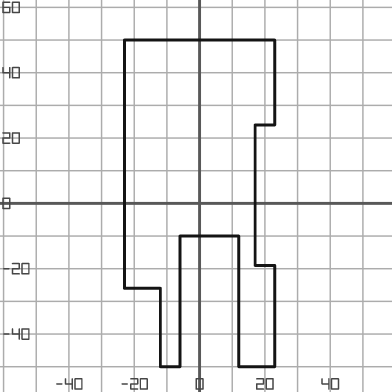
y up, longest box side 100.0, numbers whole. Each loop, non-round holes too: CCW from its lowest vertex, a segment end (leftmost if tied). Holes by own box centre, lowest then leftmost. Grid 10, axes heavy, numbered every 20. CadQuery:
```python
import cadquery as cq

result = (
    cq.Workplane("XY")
    .moveTo(-12.0, -50.0)
    .lineTo(-6.0, -50.0)
    .lineTo(-6.0, -10.0)
    .lineTo(12.0, -10.0)
    .lineTo(12.0, -50.0)
    .lineTo(23.0, -50.0)
    .lineTo(23.0, -19.0)
    .lineTo(17.0, -19.0)
    .lineTo(17.0, 24.0)
    .lineTo(23.0, 24.0)
    .lineTo(23.0, 50.0)
    .lineTo(-23.0, 50.0)
    .lineTo(-23.0, -26.0)
    .lineTo(-12.0, -26.0)
    .close()
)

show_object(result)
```